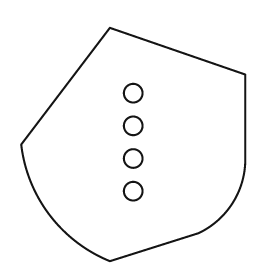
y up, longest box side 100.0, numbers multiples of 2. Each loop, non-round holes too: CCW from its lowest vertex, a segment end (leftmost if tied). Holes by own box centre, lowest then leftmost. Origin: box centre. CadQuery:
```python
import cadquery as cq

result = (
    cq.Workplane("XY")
    .moveTo(-10.0, -50.0)
    .lineTo(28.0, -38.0)
    .threePointArc((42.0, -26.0), (48.0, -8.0))
    .lineTo(48.0, 30.0)
    .lineTo(-10.0, 50.0)
    .lineTo(-48.0, 0.0)
    .threePointArc((-36.0, -30.0), (-10.0, -50.0))
    .close()
    .moveTo(0.0, -20.0)
    .circle(4.0)
    .moveTo(0.0, -6.0)
    .circle(4.0)
    .moveTo(0.0, 8.0)
    .circle(4.0)
    .moveTo(0.0, 22.0)
    .circle(4.0)
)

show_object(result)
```